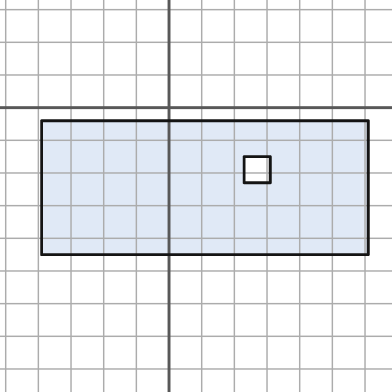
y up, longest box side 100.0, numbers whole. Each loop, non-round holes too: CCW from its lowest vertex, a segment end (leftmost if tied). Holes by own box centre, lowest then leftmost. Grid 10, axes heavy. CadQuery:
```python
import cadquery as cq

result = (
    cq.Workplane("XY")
    .moveTo(-39.0, -45.0)
    .lineTo(61.0, -45.0)
    .lineTo(61.0, -4.0)
    .lineTo(-39.0, -4.0)
    .close()
    .moveTo(23.0, -23.0)
    .lineTo(31.0, -23.0)
    .lineTo(31.0, -15.0)
    .lineTo(23.0, -15.0)
    .close()
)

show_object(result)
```